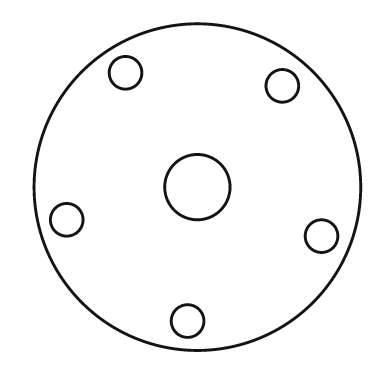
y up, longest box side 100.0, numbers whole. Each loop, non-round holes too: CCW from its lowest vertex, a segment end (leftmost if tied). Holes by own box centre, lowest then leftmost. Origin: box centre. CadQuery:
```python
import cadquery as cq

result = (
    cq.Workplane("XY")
    .moveTo(0.0, 0.0)
    .circle(50.0)
    .moveTo(-3.0, -41.0)
    .circle(5.0)
    .moveTo(38.0, -15.0)
    .circle(5.0)
    .moveTo(-40.0, -10.0)
    .circle(5.0)
    .moveTo(0.0, 0.0)
    .circle(10.0)
    .moveTo(26.0, 31.0)
    .circle(5.0)
    .moveTo(-22.0, 35.0)
    .circle(5.0)
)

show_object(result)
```